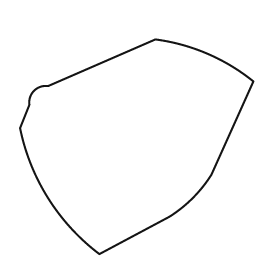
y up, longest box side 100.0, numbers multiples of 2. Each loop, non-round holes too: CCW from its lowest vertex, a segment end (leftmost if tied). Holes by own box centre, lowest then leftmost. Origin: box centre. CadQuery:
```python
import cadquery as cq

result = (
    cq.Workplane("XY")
    .moveTo(-16.0, -46.0)
    .lineTo(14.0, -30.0)
    .threePointArc((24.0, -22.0), (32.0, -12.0))
    .lineTo(50.0, 28.0)
    .threePointArc((30.0, 40.0), (8.0, 46.0))
    .lineTo(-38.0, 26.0)
    .threePointArc((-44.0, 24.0), (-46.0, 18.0))
    .lineTo(-50.0, 8.0)
    .threePointArc((-38.0, -22.0), (-16.0, -46.0))
    .close()
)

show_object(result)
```